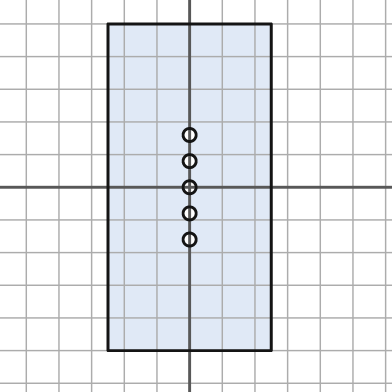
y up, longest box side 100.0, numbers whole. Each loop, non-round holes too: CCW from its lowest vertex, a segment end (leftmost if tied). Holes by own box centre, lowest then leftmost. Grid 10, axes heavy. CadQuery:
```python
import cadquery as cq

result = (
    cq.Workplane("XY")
    .moveTo(-25.0, -50.0)
    .lineTo(25.0, -50.0)
    .lineTo(25.0, 50.0)
    .lineTo(-25.0, 50.0)
    .close()
    .moveTo(0.0, -16.0)
    .circle(2.0)
    .moveTo(0.0, -8.0)
    .circle(2.0)
    .moveTo(0.0, 0.0)
    .circle(2.0)
    .moveTo(0.0, 8.0)
    .circle(2.0)
    .moveTo(0.0, 16.0)
    .circle(2.0)
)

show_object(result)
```